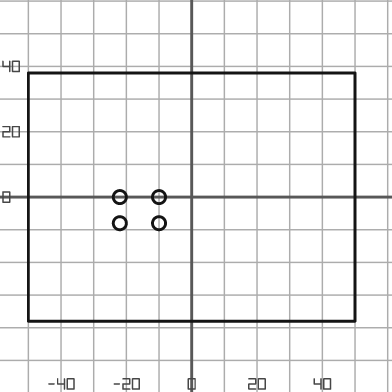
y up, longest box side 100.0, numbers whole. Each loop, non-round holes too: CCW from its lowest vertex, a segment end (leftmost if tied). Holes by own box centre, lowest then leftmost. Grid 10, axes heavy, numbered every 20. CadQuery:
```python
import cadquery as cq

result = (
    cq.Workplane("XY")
    .moveTo(-50.0, -38.0)
    .lineTo(50.0, -38.0)
    .lineTo(50.0, 38.0)
    .lineTo(-50.0, 38.0)
    .close()
    .moveTo(-22.0, -8.0)
    .circle(2.0)
    .moveTo(-10.0, -8.0)
    .circle(2.0)
    .moveTo(-22.0, 0.0)
    .circle(2.0)
    .moveTo(-10.0, 0.0)
    .circle(2.0)
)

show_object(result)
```